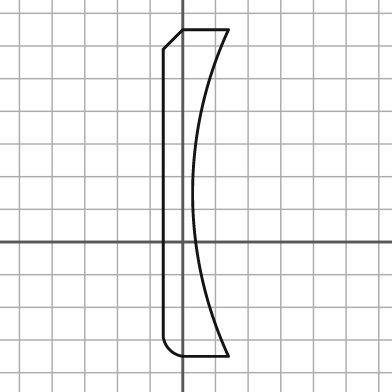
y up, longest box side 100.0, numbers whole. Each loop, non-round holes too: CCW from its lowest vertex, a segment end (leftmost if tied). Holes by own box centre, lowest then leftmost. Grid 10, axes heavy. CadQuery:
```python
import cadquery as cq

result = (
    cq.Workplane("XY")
    .moveTo(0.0, -35.0)
    .lineTo(14.0, -35.0)
    .threePointArc((3.0, 15.0), (14.0, 65.0))
    .lineTo(0.0, 65.0)
    .lineTo(-6.0, 59.0)
    .lineTo(-6.0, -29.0)
    .threePointArc((-4.0, -33.0), (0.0, -35.0))
    .close()
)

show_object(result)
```